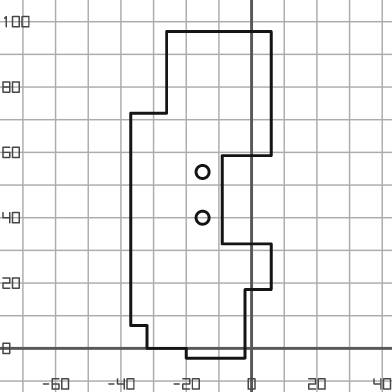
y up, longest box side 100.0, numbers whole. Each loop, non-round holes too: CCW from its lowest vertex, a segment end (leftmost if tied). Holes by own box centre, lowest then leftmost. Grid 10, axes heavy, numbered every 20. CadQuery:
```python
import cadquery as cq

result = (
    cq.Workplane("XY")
    .moveTo(-20.0, -3.0)
    .lineTo(-2.0, -3.0)
    .lineTo(-2.0, 18.0)
    .lineTo(6.0, 18.0)
    .lineTo(6.0, 32.0)
    .lineTo(-9.0, 32.0)
    .lineTo(-9.0, 59.0)
    .lineTo(6.0, 59.0)
    .lineTo(6.0, 97.0)
    .lineTo(-26.0, 97.0)
    .lineTo(-26.0, 72.0)
    .lineTo(-37.0, 72.0)
    .lineTo(-37.0, 7.0)
    .lineTo(-32.0, 7.0)
    .lineTo(-32.0, 0.0)
    .lineTo(-20.0, 0.0)
    .close()
    .moveTo(-15.0, 40.0)
    .circle(2.0)
    .moveTo(-15.0, 54.0)
    .circle(2.0)
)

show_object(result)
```